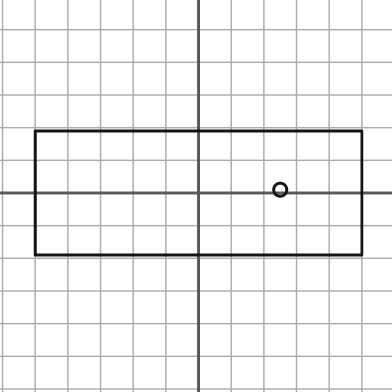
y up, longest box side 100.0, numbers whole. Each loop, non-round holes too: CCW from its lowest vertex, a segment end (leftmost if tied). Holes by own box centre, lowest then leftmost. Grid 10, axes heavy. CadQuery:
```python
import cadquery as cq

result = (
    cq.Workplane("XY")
    .moveTo(-50.0, -19.0)
    .lineTo(50.0, -19.0)
    .lineTo(50.0, 19.0)
    .lineTo(-50.0, 19.0)
    .close()
    .moveTo(25.0, 1.0)
    .circle(2.0)
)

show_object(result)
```